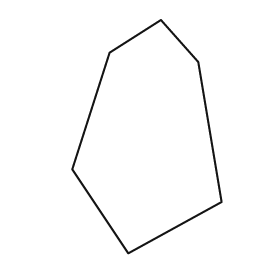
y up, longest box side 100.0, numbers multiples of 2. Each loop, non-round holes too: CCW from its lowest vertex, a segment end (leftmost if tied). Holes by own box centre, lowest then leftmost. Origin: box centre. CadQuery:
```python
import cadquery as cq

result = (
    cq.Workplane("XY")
    .moveTo(-8.0, -50.0)
    .lineTo(32.0, -28.0)
    .lineTo(22.0, 32.0)
    .lineTo(6.0, 50.0)
    .lineTo(-16.0, 36.0)
    .lineTo(-32.0, -14.0)
    .close()
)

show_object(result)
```